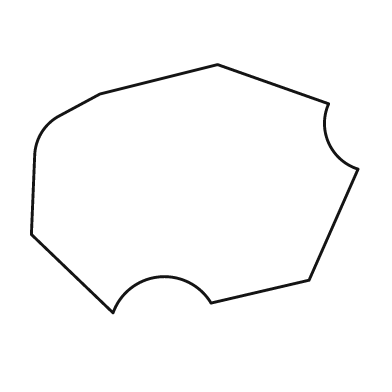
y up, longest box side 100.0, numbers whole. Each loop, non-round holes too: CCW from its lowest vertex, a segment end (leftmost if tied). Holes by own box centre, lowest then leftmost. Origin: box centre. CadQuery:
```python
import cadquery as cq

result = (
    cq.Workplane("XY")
    .moveTo(-25.0, -38.0)
    .threePointArc((-11.0, -27.0), (5.0, -35.0))
    .lineTo(35.0, -28.0)
    .lineTo(50.0, 6.0)
    .threePointArc((41.0, 14.0), (41.0, 26.0))
    .lineTo(7.0, 38.0)
    .lineTo(-29.0, 29.0)
    .lineTo(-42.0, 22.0)
    .threePointArc((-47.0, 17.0), (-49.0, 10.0))
    .lineTo(-50.0, -14.0)
    .close()
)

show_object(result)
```